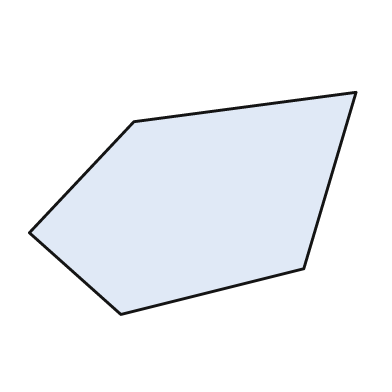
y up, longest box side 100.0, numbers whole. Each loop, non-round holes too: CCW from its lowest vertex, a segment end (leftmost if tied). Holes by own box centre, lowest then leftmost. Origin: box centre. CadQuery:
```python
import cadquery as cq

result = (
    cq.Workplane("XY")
    .moveTo(-22.0, -34.0)
    .lineTo(34.0, -20.0)
    .lineTo(50.0, 34.0)
    .lineTo(-18.0, 25.0)
    .lineTo(-50.0, -9.0)
    .close()
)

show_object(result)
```